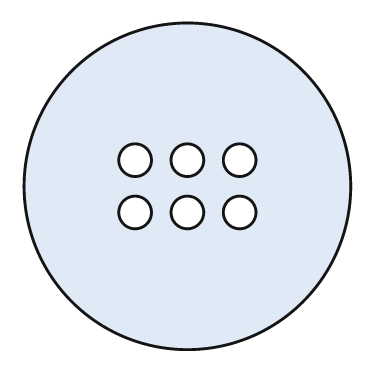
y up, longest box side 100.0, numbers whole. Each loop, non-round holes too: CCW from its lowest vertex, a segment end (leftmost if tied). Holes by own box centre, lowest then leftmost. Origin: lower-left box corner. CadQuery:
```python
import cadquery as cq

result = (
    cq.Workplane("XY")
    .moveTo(50.0, 50.0)
    .circle(50.0)
    .moveTo(34.0, 42.0)
    .circle(5.0)
    .moveTo(50.0, 42.0)
    .circle(5.0)
    .moveTo(66.0, 42.0)
    .circle(5.0)
    .moveTo(34.0, 58.0)
    .circle(5.0)
    .moveTo(50.0, 58.0)
    .circle(5.0)
    .moveTo(66.0, 58.0)
    .circle(5.0)
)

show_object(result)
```